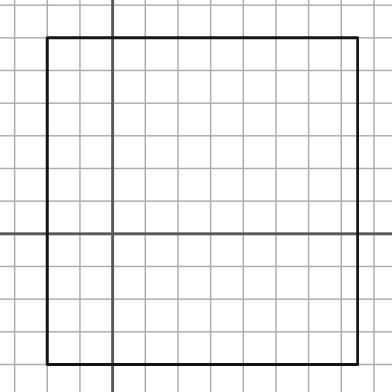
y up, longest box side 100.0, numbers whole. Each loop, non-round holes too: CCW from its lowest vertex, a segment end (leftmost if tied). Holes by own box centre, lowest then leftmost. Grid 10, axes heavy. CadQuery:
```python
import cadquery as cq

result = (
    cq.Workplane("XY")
    .moveTo(-20.0, -40.0)
    .lineTo(75.0, -40.0)
    .lineTo(75.0, 60.0)
    .lineTo(-20.0, 60.0)
    .close()
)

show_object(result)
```